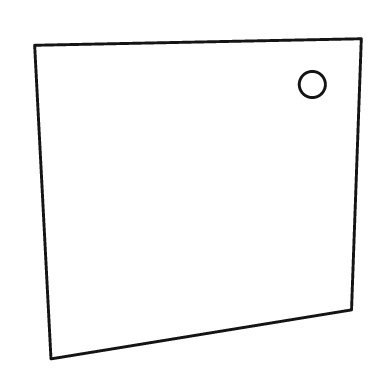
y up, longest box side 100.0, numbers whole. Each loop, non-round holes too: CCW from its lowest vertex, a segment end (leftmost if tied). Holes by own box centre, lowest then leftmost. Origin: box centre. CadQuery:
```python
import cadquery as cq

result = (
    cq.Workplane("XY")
    .moveTo(-45.0, -49.0)
    .lineTo(47.0, -34.0)
    .lineTo(50.0, 49.0)
    .lineTo(-50.0, 47.0)
    .close()
    .moveTo(35.0, 35.0)
    .circle(4.0)
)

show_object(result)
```